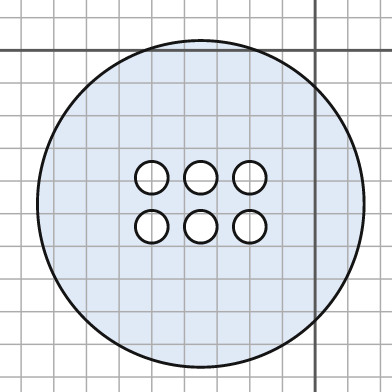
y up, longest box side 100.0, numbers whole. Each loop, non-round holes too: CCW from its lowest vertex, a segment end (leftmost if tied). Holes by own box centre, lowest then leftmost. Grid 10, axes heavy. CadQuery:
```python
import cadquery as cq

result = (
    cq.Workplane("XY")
    .moveTo(-35.0, -47.0)
    .circle(50.0)
    .moveTo(-50.0, -54.0)
    .circle(5.0)
    .moveTo(-35.0, -54.0)
    .circle(5.0)
    .moveTo(-20.0, -54.0)
    .circle(5.0)
    .moveTo(-50.0, -39.0)
    .circle(5.0)
    .moveTo(-35.0, -39.0)
    .circle(5.0)
    .moveTo(-20.0, -39.0)
    .circle(5.0)
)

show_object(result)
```